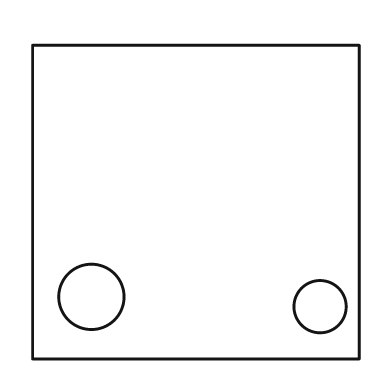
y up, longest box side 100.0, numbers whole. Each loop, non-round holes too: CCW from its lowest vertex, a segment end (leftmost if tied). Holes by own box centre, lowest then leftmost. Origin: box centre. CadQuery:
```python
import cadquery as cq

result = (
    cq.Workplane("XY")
    .moveTo(-50.0, -48.0)
    .lineTo(50.0, -48.0)
    .lineTo(50.0, 48.0)
    .lineTo(-50.0, 48.0)
    .close()
    .moveTo(38.0, -32.0)
    .circle(8.0)
    .moveTo(-32.0, -29.0)
    .circle(10.0)
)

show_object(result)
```